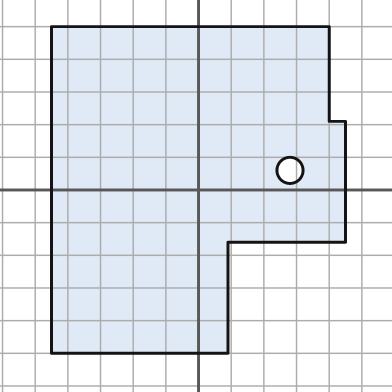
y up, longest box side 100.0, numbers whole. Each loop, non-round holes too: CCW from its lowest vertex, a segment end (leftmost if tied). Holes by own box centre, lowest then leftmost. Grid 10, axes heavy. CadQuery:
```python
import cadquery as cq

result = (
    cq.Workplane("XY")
    .moveTo(-45.0, -50.0)
    .lineTo(9.0, -50.0)
    .lineTo(9.0, -16.0)
    .lineTo(45.0, -16.0)
    .lineTo(45.0, 21.0)
    .lineTo(40.0, 21.0)
    .lineTo(40.0, 50.0)
    .lineTo(-45.0, 50.0)
    .close()
    .moveTo(28.0, 6.0)
    .circle(4.0)
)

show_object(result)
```